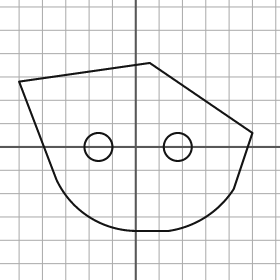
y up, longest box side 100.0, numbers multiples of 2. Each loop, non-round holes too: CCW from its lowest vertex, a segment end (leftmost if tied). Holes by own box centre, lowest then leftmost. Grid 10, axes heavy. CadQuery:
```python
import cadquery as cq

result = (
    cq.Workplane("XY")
    .moveTo(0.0, -36.0)
    .lineTo(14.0, -36.0)
    .threePointArc((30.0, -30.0), (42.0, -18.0))
    .lineTo(50.0, 6.0)
    .lineTo(6.0, 36.0)
    .lineTo(-50.0, 28.0)
    .lineTo(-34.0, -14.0)
    .threePointArc((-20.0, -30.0), (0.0, -36.0))
    .close()
    .moveTo(-16.0, 0.0)
    .circle(6.0)
    .moveTo(18.0, 0.0)
    .circle(6.0)
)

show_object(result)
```